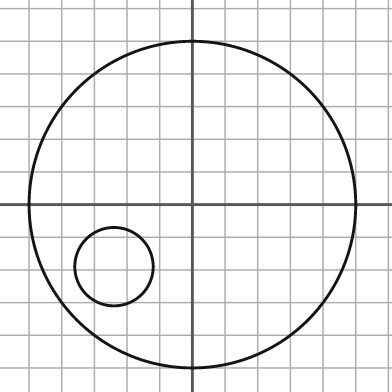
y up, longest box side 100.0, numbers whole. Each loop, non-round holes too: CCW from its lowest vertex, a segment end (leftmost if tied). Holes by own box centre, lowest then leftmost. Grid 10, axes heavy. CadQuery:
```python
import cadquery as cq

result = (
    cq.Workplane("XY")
    .moveTo(0.0, 0.0)
    .circle(50.0)
    .moveTo(-24.0, -19.0)
    .circle(12.0)
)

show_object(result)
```